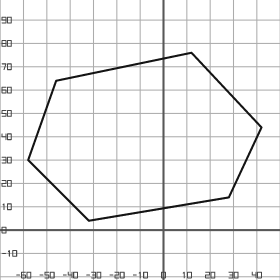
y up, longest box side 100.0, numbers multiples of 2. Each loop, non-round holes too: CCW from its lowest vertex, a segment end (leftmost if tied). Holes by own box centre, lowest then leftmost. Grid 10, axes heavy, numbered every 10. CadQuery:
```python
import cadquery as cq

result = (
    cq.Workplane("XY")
    .moveTo(-32.0, 4.0)
    .lineTo(28.0, 14.0)
    .lineTo(42.0, 44.0)
    .lineTo(12.0, 76.0)
    .lineTo(-46.0, 64.0)
    .lineTo(-58.0, 30.0)
    .close()
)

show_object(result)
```